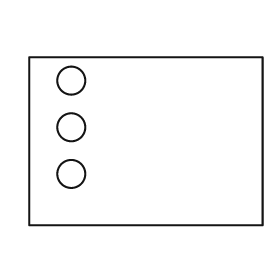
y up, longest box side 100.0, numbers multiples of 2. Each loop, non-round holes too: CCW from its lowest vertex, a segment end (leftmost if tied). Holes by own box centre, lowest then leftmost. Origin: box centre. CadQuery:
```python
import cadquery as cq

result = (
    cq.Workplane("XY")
    .moveTo(-50.0, -36.0)
    .lineTo(50.0, -36.0)
    .lineTo(50.0, 36.0)
    .lineTo(-50.0, 36.0)
    .close()
    .moveTo(-32.0, -14.0)
    .circle(6.0)
    .moveTo(-32.0, 6.0)
    .circle(6.0)
    .moveTo(-32.0, 26.0)
    .circle(6.0)
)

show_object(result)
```